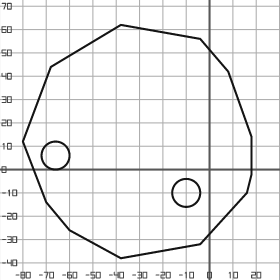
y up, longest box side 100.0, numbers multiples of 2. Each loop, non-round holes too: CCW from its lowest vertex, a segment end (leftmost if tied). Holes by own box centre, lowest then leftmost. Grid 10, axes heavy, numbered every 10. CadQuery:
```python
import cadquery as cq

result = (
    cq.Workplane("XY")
    .moveTo(-38.0, -38.0)
    .lineTo(-4.0, -32.0)
    .lineTo(16.0, -10.0)
    .lineTo(18.0, -2.0)
    .lineTo(18.0, 14.0)
    .lineTo(8.0, 42.0)
    .lineTo(-4.0, 56.0)
    .lineTo(-38.0, 62.0)
    .lineTo(-68.0, 44.0)
    .lineTo(-80.0, 12.0)
    .lineTo(-70.0, -14.0)
    .lineTo(-60.0, -26.0)
    .close()
    .moveTo(-10.0, -10.0)
    .circle(6.0)
    .moveTo(-66.0, 6.0)
    .circle(6.0)
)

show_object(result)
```